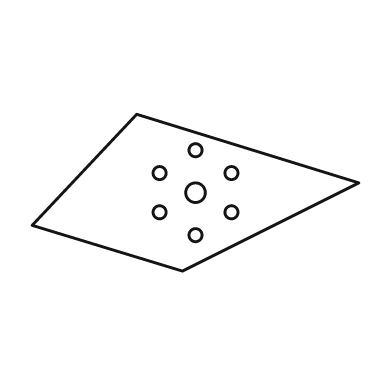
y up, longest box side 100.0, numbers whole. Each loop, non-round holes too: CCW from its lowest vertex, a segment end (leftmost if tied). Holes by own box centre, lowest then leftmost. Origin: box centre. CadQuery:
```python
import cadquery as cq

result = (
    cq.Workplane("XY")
    .moveTo(-4.0, -24.0)
    .lineTo(50.0, 3.0)
    .lineTo(-18.0, 24.0)
    .lineTo(-50.0, -10.0)
    .close()
    .moveTo(0.0, -13.0)
    .circle(2.0)
    .moveTo(-11.0, -6.0)
    .circle(2.0)
    .moveTo(11.0, -6.0)
    .circle(2.0)
    .moveTo(0.0, 0.0)
    .circle(3.0)
    .moveTo(-11.0, 6.0)
    .circle(2.0)
    .moveTo(11.0, 6.0)
    .circle(2.0)
    .moveTo(0.0, 13.0)
    .circle(2.0)
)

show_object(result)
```